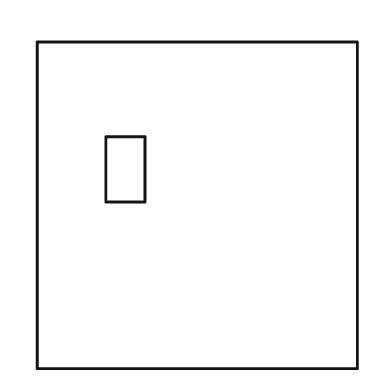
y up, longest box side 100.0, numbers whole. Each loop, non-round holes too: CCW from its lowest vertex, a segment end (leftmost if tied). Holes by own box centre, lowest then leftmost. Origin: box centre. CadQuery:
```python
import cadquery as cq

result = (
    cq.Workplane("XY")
    .moveTo(-49.0, -50.0)
    .lineTo(49.0, -50.0)
    .lineTo(49.0, 50.0)
    .lineTo(-49.0, 50.0)
    .close()
    .moveTo(-28.0, 1.0)
    .lineTo(-16.0, 1.0)
    .lineTo(-16.0, 21.0)
    .lineTo(-28.0, 21.0)
    .close()
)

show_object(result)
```